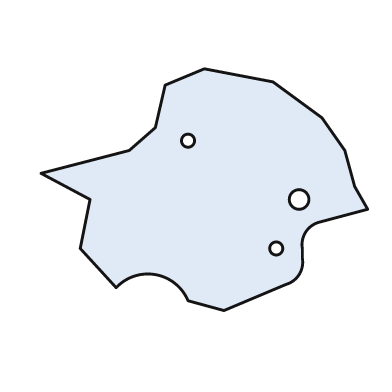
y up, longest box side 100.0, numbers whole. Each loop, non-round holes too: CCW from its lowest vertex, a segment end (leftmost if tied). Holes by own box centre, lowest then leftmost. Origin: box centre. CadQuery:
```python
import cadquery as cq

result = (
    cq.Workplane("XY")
    .moveTo(6.0, -37.0)
    .lineTo(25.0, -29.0)
    .threePointArc((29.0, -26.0), (30.0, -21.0))
    .lineTo(30.0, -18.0)
    .threePointArc((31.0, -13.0), (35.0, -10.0))
    .lineTo(50.0, -6.0)
    .lineTo(46.0, 1.0)
    .lineTo(43.0, 12.0)
    .lineTo(36.0, 22.0)
    .lineTo(21.0, 33.0)
    .lineTo(0.0, 37.0)
    .lineTo(-12.0, 32.0)
    .lineTo(-15.0, 19.0)
    .lineTo(-23.0, 12.0)
    .lineTo(-50.0, 5.0)
    .lineTo(-35.0, -3.0)
    .lineTo(-38.0, -18.0)
    .lineTo(-27.0, -30.0)
    .threePointArc((-15.0, -26.0), (-5.0, -34.0))
    .close()
    .moveTo(22.0, -18.0)
    .circle(2.0)
    .moveTo(29.0, -3.0)
    .circle(3.0)
    .moveTo(-5.0, 15.0)
    .circle(2.0)
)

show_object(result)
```